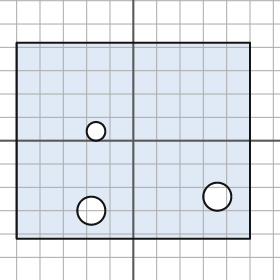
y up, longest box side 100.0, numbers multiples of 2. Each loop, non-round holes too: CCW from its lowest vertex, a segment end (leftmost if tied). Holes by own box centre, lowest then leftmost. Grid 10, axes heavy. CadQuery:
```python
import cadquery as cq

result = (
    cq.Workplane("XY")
    .moveTo(-50.0, -42.0)
    .lineTo(50.0, -42.0)
    .lineTo(50.0, 42.0)
    .lineTo(-50.0, 42.0)
    .close()
    .moveTo(-18.0, -30.0)
    .circle(6.0)
    .moveTo(36.0, -24.0)
    .circle(6.0)
    .moveTo(-16.0, 4.0)
    .circle(4.0)
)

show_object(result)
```